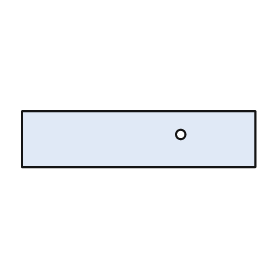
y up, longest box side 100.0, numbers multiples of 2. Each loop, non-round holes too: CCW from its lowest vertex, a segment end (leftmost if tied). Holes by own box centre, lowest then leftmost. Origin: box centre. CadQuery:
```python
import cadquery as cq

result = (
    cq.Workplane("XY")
    .moveTo(-50.0, -12.0)
    .lineTo(50.0, -12.0)
    .lineTo(50.0, 12.0)
    .lineTo(-50.0, 12.0)
    .close()
    .moveTo(18.0, 2.0)
    .circle(2.0)
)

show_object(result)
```